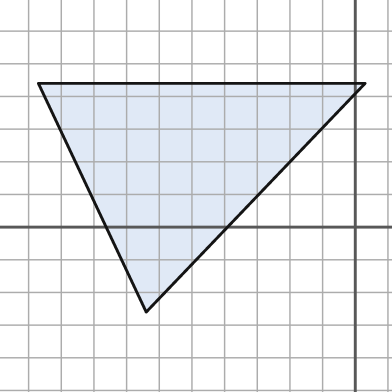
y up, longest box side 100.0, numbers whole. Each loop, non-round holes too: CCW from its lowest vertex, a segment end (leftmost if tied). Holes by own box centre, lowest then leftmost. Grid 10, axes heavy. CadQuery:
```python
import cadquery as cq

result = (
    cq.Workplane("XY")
    .moveTo(-64.0, -26.0)
    .lineTo(3.0, 44.0)
    .lineTo(-97.0, 44.0)
    .close()
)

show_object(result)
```